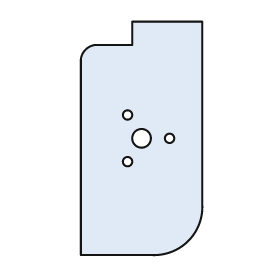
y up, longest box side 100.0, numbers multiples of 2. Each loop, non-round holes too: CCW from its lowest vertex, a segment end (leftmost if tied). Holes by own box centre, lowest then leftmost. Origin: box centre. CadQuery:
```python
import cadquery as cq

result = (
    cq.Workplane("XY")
    .moveTo(-26.0, -50.0)
    .lineTo(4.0, -50.0)
    .threePointArc((20.0, -44.0), (26.0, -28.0))
    .lineTo(26.0, 50.0)
    .lineTo(-4.0, 50.0)
    .lineTo(-4.0, 40.0)
    .lineTo(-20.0, 40.0)
    .threePointArc((-24.0, 38.0), (-26.0, 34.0))
    .close()
    .moveTo(-6.0, -10.0)
    .circle(2.0)
    .moveTo(0.0, 0.0)
    .circle(4.0)
    .moveTo(12.0, 0.0)
    .circle(2.0)
    .moveTo(-6.0, 10.0)
    .circle(2.0)
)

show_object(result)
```